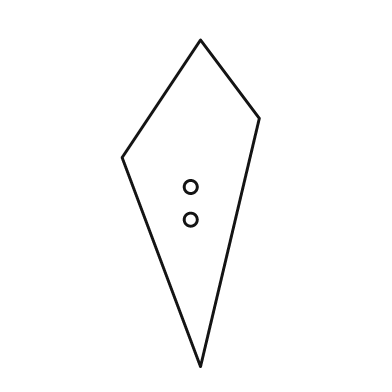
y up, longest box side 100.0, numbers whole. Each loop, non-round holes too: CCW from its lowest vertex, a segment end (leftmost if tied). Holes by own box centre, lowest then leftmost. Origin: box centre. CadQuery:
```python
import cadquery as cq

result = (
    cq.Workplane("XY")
    .moveTo(3.0, -50.0)
    .lineTo(21.0, 26.0)
    .lineTo(3.0, 50.0)
    .lineTo(-21.0, 14.0)
    .close()
    .moveTo(0.0, -5.0)
    .circle(2.0)
    .moveTo(0.0, 5.0)
    .circle(2.0)
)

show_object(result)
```